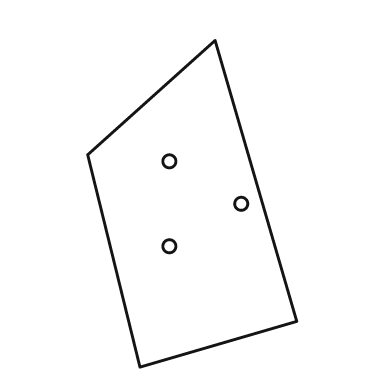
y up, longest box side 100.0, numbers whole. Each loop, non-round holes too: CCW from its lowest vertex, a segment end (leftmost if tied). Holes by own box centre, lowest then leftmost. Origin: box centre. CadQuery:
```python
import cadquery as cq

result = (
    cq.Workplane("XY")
    .moveTo(-16.0, -50.0)
    .lineTo(32.0, -36.0)
    .lineTo(7.0, 50.0)
    .lineTo(-32.0, 15.0)
    .close()
    .moveTo(-7.0, -13.0)
    .circle(2.0)
    .moveTo(15.0, 0.0)
    .circle(2.0)
    .moveTo(-7.0, 13.0)
    .circle(2.0)
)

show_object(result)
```